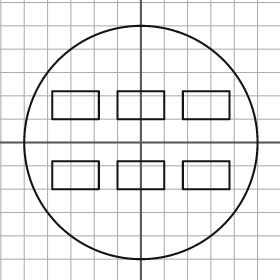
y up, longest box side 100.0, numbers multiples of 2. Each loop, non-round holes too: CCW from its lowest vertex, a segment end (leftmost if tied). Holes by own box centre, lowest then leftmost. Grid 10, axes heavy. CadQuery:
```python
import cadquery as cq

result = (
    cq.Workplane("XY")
    .moveTo(0.0, 0.0)
    .circle(50.0)
    .moveTo(-38.0, -20.0)
    .lineTo(-18.0, -20.0)
    .lineTo(-18.0, -8.0)
    .lineTo(-38.0, -8.0)
    .close()
    .moveTo(-10.0, -20.0)
    .lineTo(10.0, -20.0)
    .lineTo(10.0, -8.0)
    .lineTo(-10.0, -8.0)
    .close()
    .moveTo(18.0, -20.0)
    .lineTo(38.0, -20.0)
    .lineTo(38.0, -8.0)
    .lineTo(18.0, -8.0)
    .close()
    .moveTo(-38.0, 10.0)
    .lineTo(-18.0, 10.0)
    .lineTo(-18.0, 22.0)
    .lineTo(-38.0, 22.0)
    .close()
    .moveTo(-10.0, 10.0)
    .lineTo(10.0, 10.0)
    .lineTo(10.0, 22.0)
    .lineTo(-10.0, 22.0)
    .close()
    .moveTo(18.0, 10.0)
    .lineTo(38.0, 10.0)
    .lineTo(38.0, 22.0)
    .lineTo(18.0, 22.0)
    .close()
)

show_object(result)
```